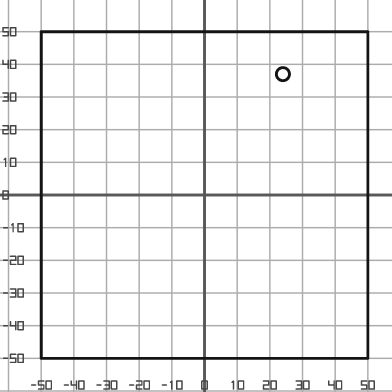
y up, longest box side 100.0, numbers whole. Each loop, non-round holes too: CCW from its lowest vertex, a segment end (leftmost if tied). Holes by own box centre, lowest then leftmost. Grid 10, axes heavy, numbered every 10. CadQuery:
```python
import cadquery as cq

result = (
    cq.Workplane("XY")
    .moveTo(-50.0, -50.0)
    .lineTo(50.0, -50.0)
    .lineTo(50.0, 50.0)
    .lineTo(-50.0, 50.0)
    .close()
    .moveTo(24.0, 37.0)
    .circle(2.0)
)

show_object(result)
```